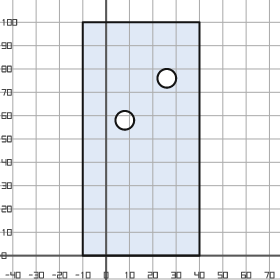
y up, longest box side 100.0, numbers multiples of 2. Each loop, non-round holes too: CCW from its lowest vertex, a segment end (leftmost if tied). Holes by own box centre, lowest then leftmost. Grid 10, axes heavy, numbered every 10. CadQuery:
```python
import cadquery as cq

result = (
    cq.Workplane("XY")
    .moveTo(-10.0, 0.0)
    .lineTo(40.0, 0.0)
    .lineTo(40.0, 100.0)
    .lineTo(-10.0, 100.0)
    .close()
    .moveTo(8.0, 58.0)
    .circle(4.0)
    .moveTo(26.0, 76.0)
    .circle(4.0)
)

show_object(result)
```